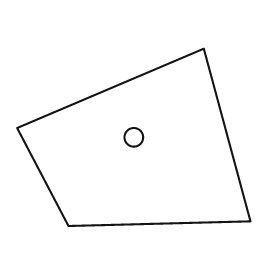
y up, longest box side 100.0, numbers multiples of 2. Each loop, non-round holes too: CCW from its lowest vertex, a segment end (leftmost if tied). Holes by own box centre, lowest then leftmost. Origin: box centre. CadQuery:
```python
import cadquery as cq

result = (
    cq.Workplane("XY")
    .moveTo(-28.0, -38.0)
    .lineTo(50.0, -36.0)
    .lineTo(30.0, 38.0)
    .lineTo(-50.0, 4.0)
    .close()
    .moveTo(0.0, 0.0)
    .circle(4.0)
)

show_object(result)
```